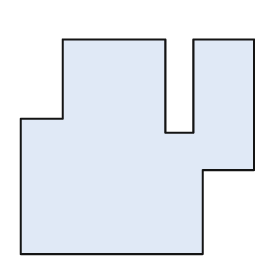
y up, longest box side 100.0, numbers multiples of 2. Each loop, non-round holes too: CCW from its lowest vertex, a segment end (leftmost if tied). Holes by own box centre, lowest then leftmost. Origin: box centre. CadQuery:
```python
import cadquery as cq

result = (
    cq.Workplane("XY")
    .moveTo(-50.0, -46.0)
    .lineTo(28.0, -46.0)
    .lineTo(28.0, -10.0)
    .lineTo(50.0, -10.0)
    .lineTo(50.0, 46.0)
    .lineTo(24.0, 46.0)
    .lineTo(24.0, 6.0)
    .lineTo(12.0, 6.0)
    .lineTo(12.0, 46.0)
    .lineTo(-32.0, 46.0)
    .lineTo(-32.0, 12.0)
    .lineTo(-50.0, 12.0)
    .close()
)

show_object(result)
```